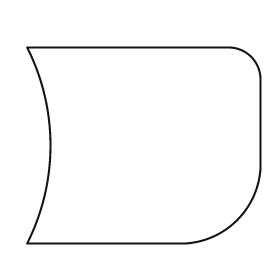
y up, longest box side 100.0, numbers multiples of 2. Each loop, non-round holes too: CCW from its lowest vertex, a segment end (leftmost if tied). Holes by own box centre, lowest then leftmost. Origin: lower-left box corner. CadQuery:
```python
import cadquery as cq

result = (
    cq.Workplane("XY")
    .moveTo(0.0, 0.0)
    .lineTo(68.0, 0.0)
    .threePointArc((90.0, 10.0), (100.0, 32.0))
    .lineTo(100.0, 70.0)
    .threePointArc((96.0, 80.0), (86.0, 84.0))
    .lineTo(0.0, 84.0)
    .threePointArc((10.0, 42.0), (0.0, 0.0))
    .close()
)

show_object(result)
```